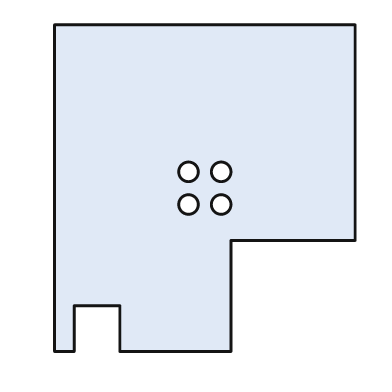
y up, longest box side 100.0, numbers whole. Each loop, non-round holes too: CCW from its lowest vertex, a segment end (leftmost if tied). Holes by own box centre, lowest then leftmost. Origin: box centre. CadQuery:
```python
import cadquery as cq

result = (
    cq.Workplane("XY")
    .moveTo(-46.0, -50.0)
    .lineTo(-40.0, -50.0)
    .lineTo(-40.0, -36.0)
    .lineTo(-26.0, -36.0)
    .lineTo(-26.0, -50.0)
    .lineTo(8.0, -50.0)
    .lineTo(8.0, -16.0)
    .lineTo(46.0, -16.0)
    .lineTo(46.0, 50.0)
    .lineTo(-46.0, 50.0)
    .close()
    .moveTo(-5.0, -5.0)
    .circle(3.0)
    .moveTo(5.0, -5.0)
    .circle(3.0)
    .moveTo(-5.0, 5.0)
    .circle(3.0)
    .moveTo(5.0, 5.0)
    .circle(3.0)
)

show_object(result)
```